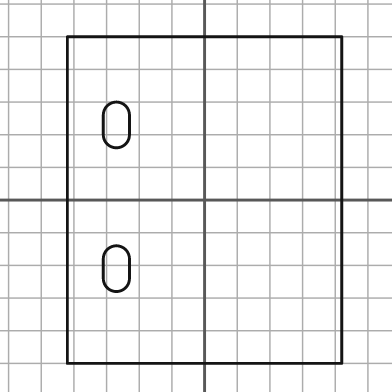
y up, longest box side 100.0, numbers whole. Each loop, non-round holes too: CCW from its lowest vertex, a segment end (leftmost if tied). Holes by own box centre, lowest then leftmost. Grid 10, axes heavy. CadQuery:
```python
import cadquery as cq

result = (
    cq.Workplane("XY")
    .moveTo(-42.0, -50.0)
    .lineTo(42.0, -50.0)
    .lineTo(42.0, 50.0)
    .lineTo(-42.0, 50.0)
    .close()
    .moveTo(-31.0, -24.0)
    .threePointArc((-27.0, -28.0), (-23.0, -24.0))
    .lineTo(-23.0, -18.0)
    .threePointArc((-27.0, -14.0), (-31.0, -18.0))
    .close()
    .moveTo(-31.0, 20.0)
    .threePointArc((-27.0, 16.0), (-23.0, 20.0))
    .lineTo(-23.0, 26.0)
    .threePointArc((-27.0, 30.0), (-31.0, 26.0))
    .close()
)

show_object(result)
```